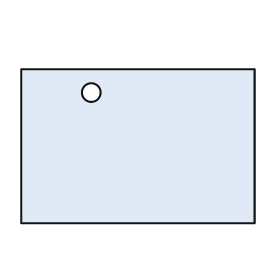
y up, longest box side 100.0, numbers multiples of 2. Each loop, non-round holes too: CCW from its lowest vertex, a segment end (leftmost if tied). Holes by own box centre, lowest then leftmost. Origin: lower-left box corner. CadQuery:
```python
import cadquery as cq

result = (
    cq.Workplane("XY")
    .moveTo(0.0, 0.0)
    .lineTo(100.0, 0.0)
    .lineTo(100.0, 66.0)
    .lineTo(0.0, 66.0)
    .close()
    .moveTo(30.0, 56.0)
    .circle(4.0)
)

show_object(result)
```